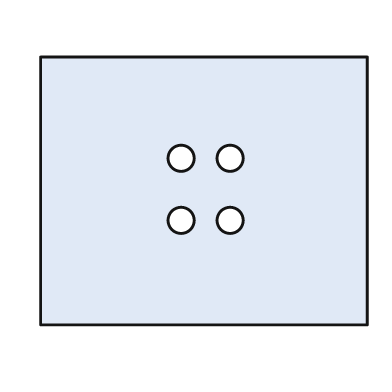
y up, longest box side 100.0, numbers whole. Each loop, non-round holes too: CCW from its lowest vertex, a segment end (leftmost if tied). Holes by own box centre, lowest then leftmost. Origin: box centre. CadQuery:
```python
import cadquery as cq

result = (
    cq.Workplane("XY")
    .moveTo(-50.0, -41.0)
    .lineTo(50.0, -41.0)
    .lineTo(50.0, 41.0)
    .lineTo(-50.0, 41.0)
    .close()
    .moveTo(-7.0, -9.0)
    .circle(4.0)
    .moveTo(8.0, -9.0)
    .circle(4.0)
    .moveTo(-7.0, 10.0)
    .circle(4.0)
    .moveTo(8.0, 10.0)
    .circle(4.0)
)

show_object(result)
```